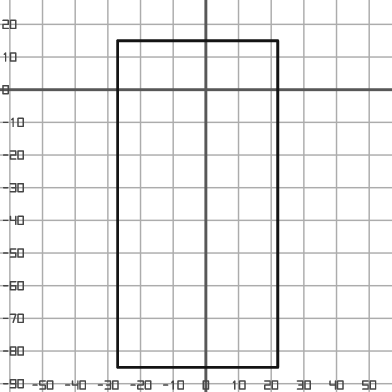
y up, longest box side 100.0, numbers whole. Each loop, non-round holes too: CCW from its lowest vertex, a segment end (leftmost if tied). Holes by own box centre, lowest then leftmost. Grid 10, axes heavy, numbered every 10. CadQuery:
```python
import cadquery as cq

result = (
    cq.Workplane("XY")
    .moveTo(-27.0, -85.0)
    .lineTo(22.0, -85.0)
    .lineTo(22.0, 15.0)
    .lineTo(-27.0, 15.0)
    .close()
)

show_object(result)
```